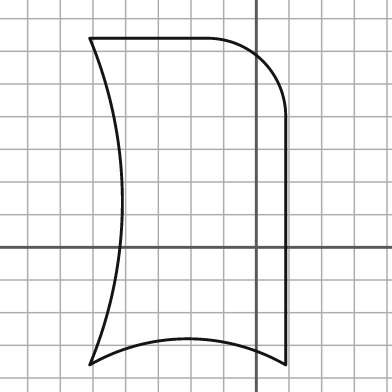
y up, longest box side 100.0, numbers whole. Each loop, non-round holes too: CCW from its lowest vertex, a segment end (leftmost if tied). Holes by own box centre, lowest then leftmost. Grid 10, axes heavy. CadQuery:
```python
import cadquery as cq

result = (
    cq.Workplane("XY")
    .moveTo(-51.0, -36.0)
    .threePointArc((-21.0, -28.0), (9.0, -36.0))
    .lineTo(9.0, 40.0)
    .threePointArc((2.0, 57.0), (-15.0, 64.0))
    .lineTo(-51.0, 64.0)
    .threePointArc((-41.0, 14.0), (-51.0, -36.0))
    .close()
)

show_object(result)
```